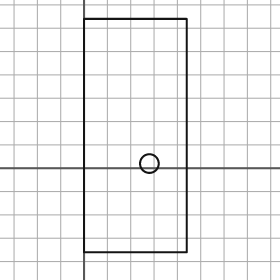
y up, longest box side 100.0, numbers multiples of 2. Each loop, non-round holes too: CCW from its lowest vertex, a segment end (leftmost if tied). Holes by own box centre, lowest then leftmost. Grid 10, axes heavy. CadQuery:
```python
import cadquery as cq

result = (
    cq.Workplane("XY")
    .moveTo(0.0, -36.0)
    .lineTo(44.0, -36.0)
    .lineTo(44.0, 64.0)
    .lineTo(0.0, 64.0)
    .close()
    .moveTo(28.0, 2.0)
    .circle(4.0)
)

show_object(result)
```